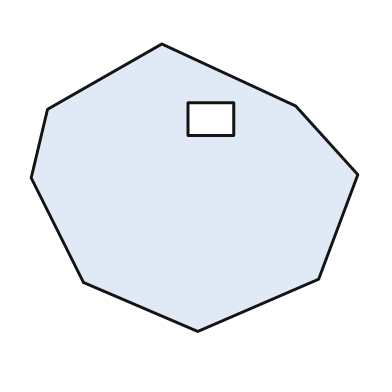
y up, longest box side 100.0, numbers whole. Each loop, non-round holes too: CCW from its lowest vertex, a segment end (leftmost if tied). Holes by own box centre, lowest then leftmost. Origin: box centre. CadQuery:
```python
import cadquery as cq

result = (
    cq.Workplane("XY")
    .moveTo(1.0, -44.0)
    .lineTo(38.0, -28.0)
    .lineTo(50.0, 4.0)
    .lineTo(31.0, 25.0)
    .lineTo(-10.0, 44.0)
    .lineTo(-45.0, 24.0)
    .lineTo(-50.0, 3.0)
    .lineTo(-34.0, -29.0)
    .close()
    .moveTo(-2.0, 16.0)
    .lineTo(12.0, 16.0)
    .lineTo(12.0, 26.0)
    .lineTo(-2.0, 26.0)
    .close()
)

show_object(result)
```